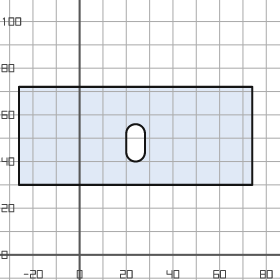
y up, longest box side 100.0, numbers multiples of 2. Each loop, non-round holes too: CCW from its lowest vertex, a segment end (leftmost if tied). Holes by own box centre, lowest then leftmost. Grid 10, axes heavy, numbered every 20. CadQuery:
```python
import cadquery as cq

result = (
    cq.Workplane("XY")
    .moveTo(-26.0, 30.0)
    .lineTo(74.0, 30.0)
    .lineTo(74.0, 72.0)
    .lineTo(-26.0, 72.0)
    .close()
    .moveTo(20.0, 44.0)
    .threePointArc((24.0, 40.0), (28.0, 44.0))
    .lineTo(28.0, 52.0)
    .threePointArc((24.0, 56.0), (20.0, 52.0))
    .close()
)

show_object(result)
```